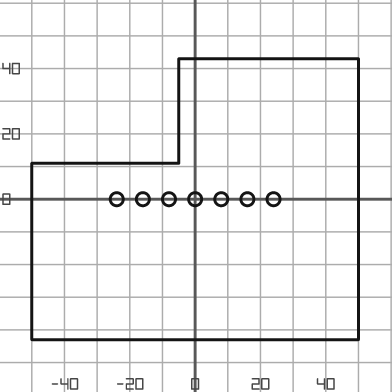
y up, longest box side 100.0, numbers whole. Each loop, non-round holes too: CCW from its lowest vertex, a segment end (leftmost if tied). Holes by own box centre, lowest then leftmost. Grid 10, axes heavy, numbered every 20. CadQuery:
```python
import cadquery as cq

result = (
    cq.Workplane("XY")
    .moveTo(-50.0, -43.0)
    .lineTo(50.0, -43.0)
    .lineTo(50.0, 43.0)
    .lineTo(-5.0, 43.0)
    .lineTo(-5.0, 11.0)
    .lineTo(-50.0, 11.0)
    .close()
    .moveTo(-24.0, 0.0)
    .circle(2.0)
    .moveTo(-16.0, 0.0)
    .circle(2.0)
    .moveTo(-8.0, 0.0)
    .circle(2.0)
    .moveTo(0.0, 0.0)
    .circle(2.0)
    .moveTo(8.0, 0.0)
    .circle(2.0)
    .moveTo(16.0, 0.0)
    .circle(2.0)
    .moveTo(24.0, 0.0)
    .circle(2.0)
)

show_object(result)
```